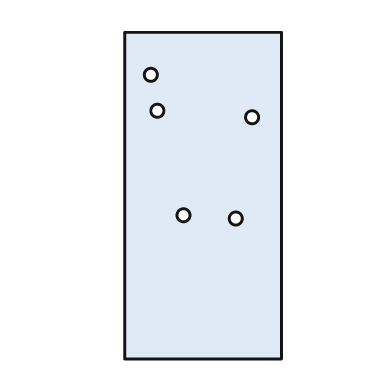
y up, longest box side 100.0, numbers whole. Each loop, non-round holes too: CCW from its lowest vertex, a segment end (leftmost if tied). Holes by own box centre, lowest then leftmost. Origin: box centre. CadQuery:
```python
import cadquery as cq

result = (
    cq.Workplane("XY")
    .moveTo(-24.0, -50.0)
    .lineTo(24.0, -50.0)
    .lineTo(24.0, 50.0)
    .lineTo(-24.0, 50.0)
    .close()
    .moveTo(10.0, -7.0)
    .circle(2.0)
    .moveTo(-6.0, -6.0)
    .circle(2.0)
    .moveTo(15.0, 24.0)
    .circle(2.0)
    .moveTo(-14.0, 26.0)
    .circle(2.0)
    .moveTo(-16.0, 37.0)
    .circle(2.0)
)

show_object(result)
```